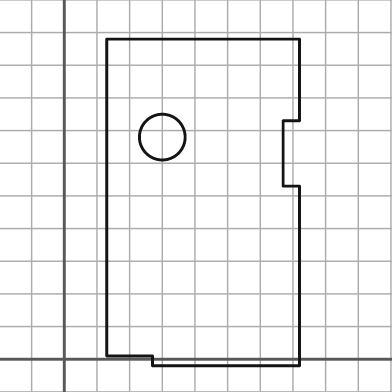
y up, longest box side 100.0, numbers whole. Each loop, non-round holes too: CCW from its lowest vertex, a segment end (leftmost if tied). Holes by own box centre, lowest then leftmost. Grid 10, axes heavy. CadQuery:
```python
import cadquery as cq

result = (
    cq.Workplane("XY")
    .moveTo(27.0, -2.0)
    .lineTo(72.0, -2.0)
    .lineTo(72.0, 53.0)
    .lineTo(67.0, 53.0)
    .lineTo(67.0, 73.0)
    .lineTo(72.0, 73.0)
    .lineTo(72.0, 98.0)
    .lineTo(13.0, 98.0)
    .lineTo(13.0, 1.0)
    .lineTo(27.0, 1.0)
    .close()
    .moveTo(30.0, 68.0)
    .circle(7.0)
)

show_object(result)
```